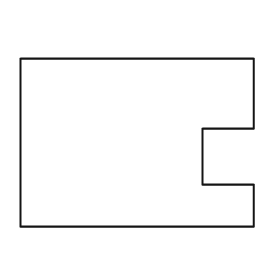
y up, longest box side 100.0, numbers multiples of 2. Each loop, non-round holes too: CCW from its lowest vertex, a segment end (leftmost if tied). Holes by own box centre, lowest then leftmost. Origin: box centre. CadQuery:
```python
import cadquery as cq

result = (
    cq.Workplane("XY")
    .moveTo(-50.0, -36.0)
    .lineTo(50.0, -36.0)
    .lineTo(50.0, -18.0)
    .lineTo(28.0, -18.0)
    .lineTo(28.0, 6.0)
    .lineTo(50.0, 6.0)
    .lineTo(50.0, 36.0)
    .lineTo(-50.0, 36.0)
    .close()
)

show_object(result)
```